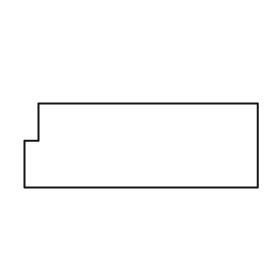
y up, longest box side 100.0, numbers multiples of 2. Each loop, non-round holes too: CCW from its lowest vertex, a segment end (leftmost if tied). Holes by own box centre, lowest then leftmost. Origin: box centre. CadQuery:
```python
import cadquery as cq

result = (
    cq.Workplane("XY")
    .moveTo(-50.0, -18.0)
    .lineTo(50.0, -18.0)
    .lineTo(50.0, 18.0)
    .lineTo(-44.0, 18.0)
    .lineTo(-44.0, 2.0)
    .lineTo(-50.0, 2.0)
    .close()
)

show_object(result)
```